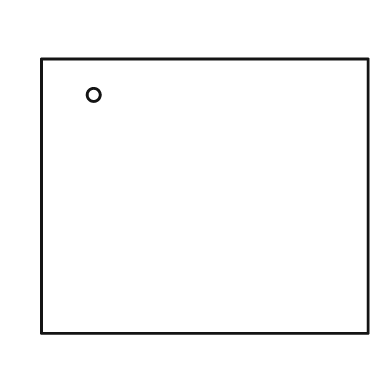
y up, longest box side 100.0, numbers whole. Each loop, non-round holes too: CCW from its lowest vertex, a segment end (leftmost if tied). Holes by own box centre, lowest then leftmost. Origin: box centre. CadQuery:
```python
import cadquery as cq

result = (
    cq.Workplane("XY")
    .moveTo(-50.0, -42.0)
    .lineTo(50.0, -42.0)
    .lineTo(50.0, 42.0)
    .lineTo(-50.0, 42.0)
    .close()
    .moveTo(-34.0, 31.0)
    .circle(2.0)
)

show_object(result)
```